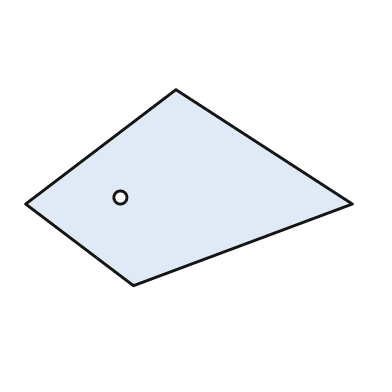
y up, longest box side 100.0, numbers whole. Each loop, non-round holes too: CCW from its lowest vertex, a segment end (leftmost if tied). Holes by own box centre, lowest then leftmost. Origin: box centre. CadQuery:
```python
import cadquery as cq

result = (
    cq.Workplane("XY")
    .moveTo(-17.0, -30.0)
    .lineTo(50.0, -5.0)
    .lineTo(-4.0, 30.0)
    .lineTo(-50.0, -5.0)
    .close()
    .moveTo(-21.0, -3.0)
    .circle(2.0)
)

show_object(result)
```